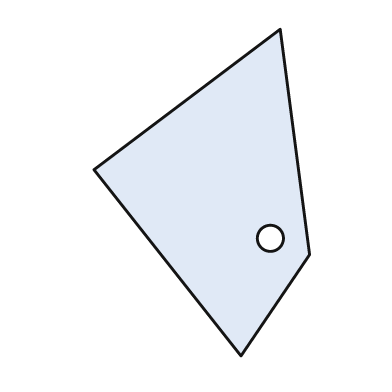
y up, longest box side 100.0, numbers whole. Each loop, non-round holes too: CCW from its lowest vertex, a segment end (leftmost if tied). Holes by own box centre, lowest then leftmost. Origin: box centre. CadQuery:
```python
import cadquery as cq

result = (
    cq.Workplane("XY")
    .moveTo(12.0, -50.0)
    .lineTo(33.0, -19.0)
    .lineTo(24.0, 50.0)
    .lineTo(-33.0, 7.0)
    .close()
    .moveTo(21.0, -14.0)
    .circle(4.0)
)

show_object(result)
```